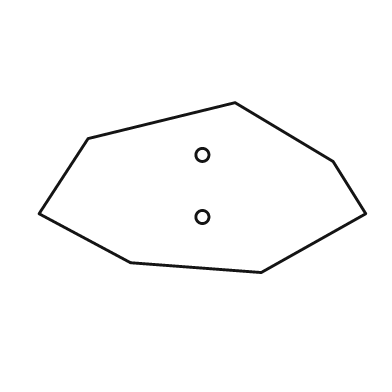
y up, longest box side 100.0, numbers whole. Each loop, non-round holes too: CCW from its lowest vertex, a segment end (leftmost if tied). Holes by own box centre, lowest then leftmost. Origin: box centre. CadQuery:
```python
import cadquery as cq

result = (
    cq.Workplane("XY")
    .moveTo(18.0, -26.0)
    .lineTo(50.0, -8.0)
    .lineTo(40.0, 8.0)
    .lineTo(10.0, 26.0)
    .lineTo(-35.0, 15.0)
    .lineTo(-50.0, -8.0)
    .lineTo(-22.0, -23.0)
    .close()
    .moveTo(0.0, -9.0)
    .circle(2.0)
    .moveTo(0.0, 10.0)
    .circle(2.0)
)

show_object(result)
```